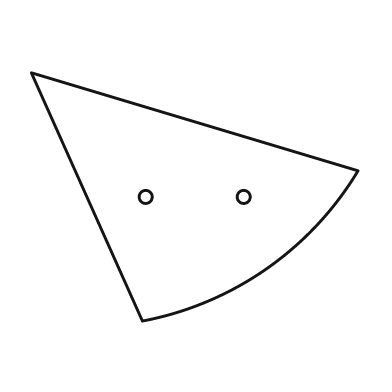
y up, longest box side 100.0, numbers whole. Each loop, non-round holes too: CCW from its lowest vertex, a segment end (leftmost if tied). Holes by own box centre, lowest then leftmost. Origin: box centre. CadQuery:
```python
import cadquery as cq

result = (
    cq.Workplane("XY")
    .moveTo(-16.0, -38.0)
    .threePointArc((22.0, -22.0), (50.0, 8.0))
    .lineTo(-50.0, 38.0)
    .close()
    .moveTo(-15.0, 0.0)
    .circle(2.0)
    .moveTo(15.0, 0.0)
    .circle(2.0)
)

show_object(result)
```